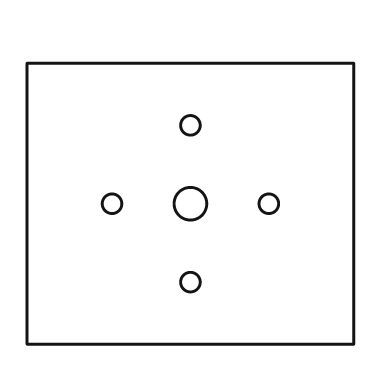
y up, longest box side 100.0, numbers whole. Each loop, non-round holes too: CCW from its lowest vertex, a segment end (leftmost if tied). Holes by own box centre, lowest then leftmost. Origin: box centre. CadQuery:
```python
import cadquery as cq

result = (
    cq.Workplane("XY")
    .moveTo(-50.0, -43.0)
    .lineTo(50.0, -43.0)
    .lineTo(50.0, 43.0)
    .lineTo(-50.0, 43.0)
    .close()
    .moveTo(0.0, -24.0)
    .circle(3.0)
    .moveTo(-24.0, 0.0)
    .circle(3.0)
    .moveTo(0.0, 0.0)
    .circle(5.0)
    .moveTo(24.0, 0.0)
    .circle(3.0)
    .moveTo(0.0, 24.0)
    .circle(3.0)
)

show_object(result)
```